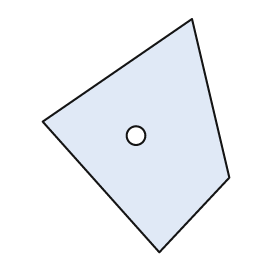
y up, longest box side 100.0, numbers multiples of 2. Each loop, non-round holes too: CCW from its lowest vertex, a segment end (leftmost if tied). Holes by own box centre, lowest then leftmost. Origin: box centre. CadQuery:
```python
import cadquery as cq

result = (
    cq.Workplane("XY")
    .moveTo(10.0, -50.0)
    .lineTo(40.0, -18.0)
    .lineTo(24.0, 50.0)
    .lineTo(-40.0, 6.0)
    .close()
    .moveTo(0.0, 0.0)
    .circle(4.0)
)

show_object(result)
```